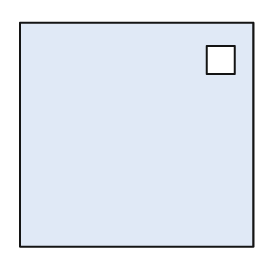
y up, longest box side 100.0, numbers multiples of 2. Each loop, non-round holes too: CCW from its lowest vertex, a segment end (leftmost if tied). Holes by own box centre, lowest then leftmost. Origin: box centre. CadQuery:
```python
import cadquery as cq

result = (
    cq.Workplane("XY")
    .moveTo(-50.0, -48.0)
    .lineTo(50.0, -48.0)
    .lineTo(50.0, 48.0)
    .lineTo(-50.0, 48.0)
    .close()
    .moveTo(30.0, 26.0)
    .lineTo(42.0, 26.0)
    .lineTo(42.0, 38.0)
    .lineTo(30.0, 38.0)
    .close()
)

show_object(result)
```